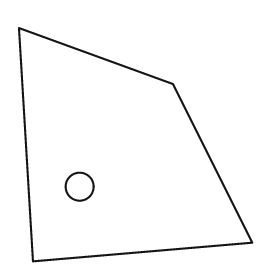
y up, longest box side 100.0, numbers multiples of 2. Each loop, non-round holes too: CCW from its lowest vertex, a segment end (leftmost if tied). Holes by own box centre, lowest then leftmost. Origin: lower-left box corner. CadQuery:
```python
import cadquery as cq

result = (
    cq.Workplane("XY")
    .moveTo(6.0, 0.0)
    .lineTo(100.0, 8.0)
    .lineTo(66.0, 76.0)
    .lineTo(0.0, 100.0)
    .close()
    .moveTo(26.0, 32.0)
    .circle(6.0)
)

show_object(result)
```